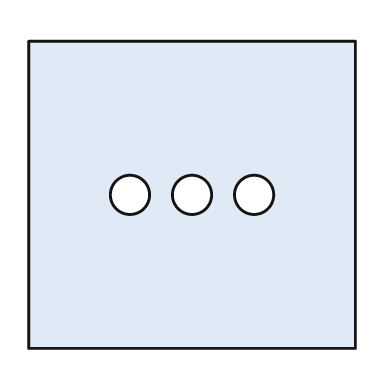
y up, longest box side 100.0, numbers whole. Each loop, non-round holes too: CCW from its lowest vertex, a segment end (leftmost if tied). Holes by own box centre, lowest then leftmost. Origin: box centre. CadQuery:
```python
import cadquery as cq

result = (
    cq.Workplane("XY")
    .moveTo(-50.0, -47.0)
    .lineTo(50.0, -47.0)
    .lineTo(50.0, 47.0)
    .lineTo(-50.0, 47.0)
    .close()
    .moveTo(-19.0, 0.0)
    .circle(6.0)
    .moveTo(0.0, 0.0)
    .circle(6.0)
    .moveTo(19.0, 0.0)
    .circle(6.0)
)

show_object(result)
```